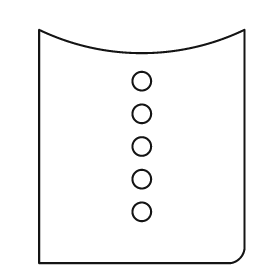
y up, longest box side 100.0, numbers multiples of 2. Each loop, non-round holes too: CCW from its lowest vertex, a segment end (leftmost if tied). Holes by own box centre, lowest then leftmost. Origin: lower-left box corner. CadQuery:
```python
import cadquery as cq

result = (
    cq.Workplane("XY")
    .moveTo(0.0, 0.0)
    .lineTo(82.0, 0.0)
    .threePointArc((86.0, 2.0), (88.0, 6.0))
    .lineTo(88.0, 100.0)
    .threePointArc((44.0, 90.0), (0.0, 100.0))
    .close()
    .moveTo(44.0, 22.0)
    .circle(4.0)
    .moveTo(44.0, 36.0)
    .circle(4.0)
    .moveTo(44.0, 50.0)
    .circle(4.0)
    .moveTo(44.0, 64.0)
    .circle(4.0)
    .moveTo(44.0, 78.0)
    .circle(4.0)
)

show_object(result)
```